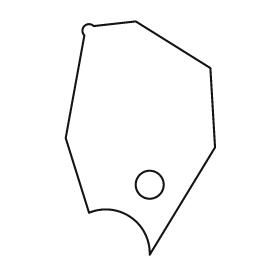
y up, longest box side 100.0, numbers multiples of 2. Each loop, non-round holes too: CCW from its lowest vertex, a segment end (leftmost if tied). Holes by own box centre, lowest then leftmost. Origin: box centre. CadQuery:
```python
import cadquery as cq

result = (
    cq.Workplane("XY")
    .moveTo(4.0, -50.0)
    .lineTo(32.0, -4.0)
    .lineTo(30.0, 30.0)
    .lineTo(-2.0, 50.0)
    .lineTo(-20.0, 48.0)
    .threePointArc((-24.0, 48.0), (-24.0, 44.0))
    .lineTo(-32.0, 0.0)
    .lineTo(-22.0, -32.0)
    .threePointArc((-4.0, -34.0), (4.0, -50.0))
    .close()
    .moveTo(4.0, -20.0)
    .circle(6.0)
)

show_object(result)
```